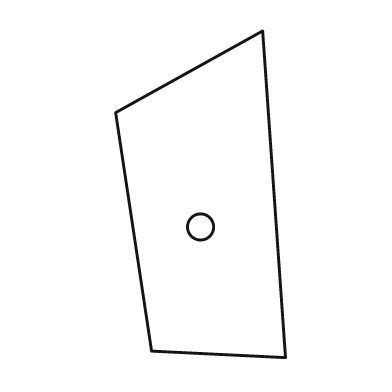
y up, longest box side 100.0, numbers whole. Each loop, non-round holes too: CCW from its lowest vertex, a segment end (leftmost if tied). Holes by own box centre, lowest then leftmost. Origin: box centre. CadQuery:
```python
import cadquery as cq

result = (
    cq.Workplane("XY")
    .moveTo(26.0, -50.0)
    .lineTo(19.0, 50.0)
    .lineTo(-26.0, 25.0)
    .lineTo(-15.0, -48.0)
    .close()
    .moveTo(0.0, -10.0)
    .circle(4.0)
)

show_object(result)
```